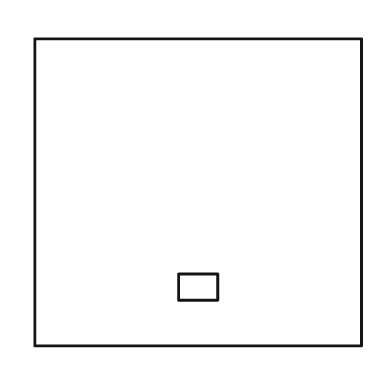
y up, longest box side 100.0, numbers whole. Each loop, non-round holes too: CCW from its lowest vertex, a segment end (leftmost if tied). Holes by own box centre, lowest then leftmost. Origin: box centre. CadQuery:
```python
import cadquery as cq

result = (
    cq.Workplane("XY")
    .moveTo(-50.0, -47.0)
    .lineTo(50.0, -47.0)
    .lineTo(50.0, 47.0)
    .lineTo(-50.0, 47.0)
    .close()
    .moveTo(-6.0, -33.0)
    .lineTo(6.0, -33.0)
    .lineTo(6.0, -25.0)
    .lineTo(-6.0, -25.0)
    .close()
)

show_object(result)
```